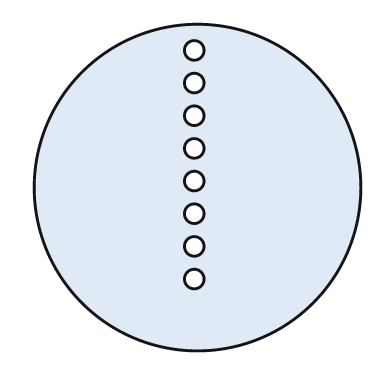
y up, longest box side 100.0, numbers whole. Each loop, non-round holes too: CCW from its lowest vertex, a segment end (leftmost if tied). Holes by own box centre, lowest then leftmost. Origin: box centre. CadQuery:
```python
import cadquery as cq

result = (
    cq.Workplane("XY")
    .moveTo(0.0, 0.0)
    .circle(50.0)
    .moveTo(-1.0, -28.0)
    .circle(3.0)
    .moveTo(-1.0, -18.0)
    .circle(3.0)
    .moveTo(-1.0, -8.0)
    .circle(3.0)
    .moveTo(-1.0, 2.0)
    .circle(3.0)
    .moveTo(-1.0, 12.0)
    .circle(3.0)
    .moveTo(-1.0, 22.0)
    .circle(3.0)
    .moveTo(-1.0, 32.0)
    .circle(3.0)
    .moveTo(-1.0, 42.0)
    .circle(3.0)
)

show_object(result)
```